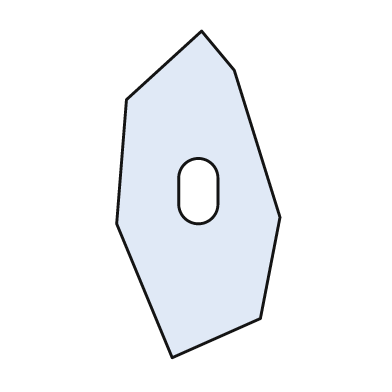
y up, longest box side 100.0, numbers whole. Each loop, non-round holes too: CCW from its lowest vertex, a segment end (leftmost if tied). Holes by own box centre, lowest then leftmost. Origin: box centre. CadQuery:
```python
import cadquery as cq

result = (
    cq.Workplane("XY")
    .moveTo(-8.0, -50.0)
    .lineTo(19.0, -38.0)
    .lineTo(25.0, -7.0)
    .lineTo(11.0, 38.0)
    .lineTo(1.0, 50.0)
    .lineTo(-22.0, 29.0)
    .lineTo(-25.0, -9.0)
    .close()
    .moveTo(-6.0, -3.0)
    .threePointArc((0.0, -9.0), (6.0, -3.0))
    .lineTo(6.0, 5.0)
    .threePointArc((0.0, 11.0), (-6.0, 5.0))
    .close()
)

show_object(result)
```